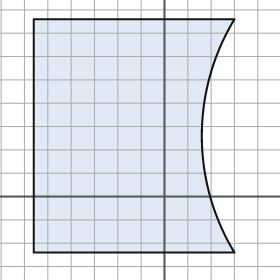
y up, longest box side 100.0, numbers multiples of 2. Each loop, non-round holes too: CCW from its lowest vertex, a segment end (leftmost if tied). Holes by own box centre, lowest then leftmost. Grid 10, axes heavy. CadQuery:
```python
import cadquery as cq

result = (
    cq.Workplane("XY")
    .moveTo(-56.0, -24.0)
    .lineTo(30.0, -24.0)
    .threePointArc((16.0, 26.0), (30.0, 76.0))
    .lineTo(-56.0, 76.0)
    .close()
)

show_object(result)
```